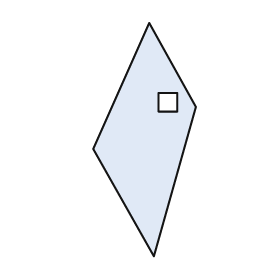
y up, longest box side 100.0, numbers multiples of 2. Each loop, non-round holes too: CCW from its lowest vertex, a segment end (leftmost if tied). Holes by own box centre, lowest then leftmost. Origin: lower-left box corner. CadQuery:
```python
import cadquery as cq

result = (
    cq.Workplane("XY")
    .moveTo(26.0, 0.0)
    .lineTo(44.0, 64.0)
    .lineTo(24.0, 100.0)
    .lineTo(0.0, 46.0)
    .close()
    .moveTo(28.0, 62.0)
    .lineTo(36.0, 62.0)
    .lineTo(36.0, 70.0)
    .lineTo(28.0, 70.0)
    .close()
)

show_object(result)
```